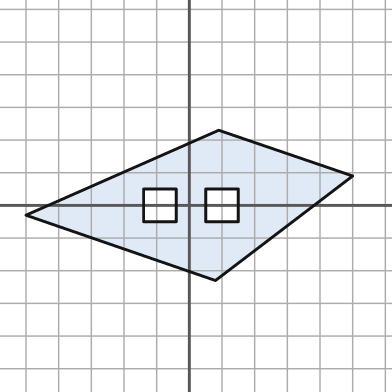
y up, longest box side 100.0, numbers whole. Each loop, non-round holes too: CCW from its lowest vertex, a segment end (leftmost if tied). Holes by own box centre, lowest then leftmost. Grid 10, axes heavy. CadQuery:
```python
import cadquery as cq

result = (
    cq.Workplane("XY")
    .moveTo(8.0, -23.0)
    .lineTo(50.0, 9.0)
    .lineTo(9.0, 23.0)
    .lineTo(-50.0, -3.0)
    .close()
    .moveTo(-14.0, -5.0)
    .lineTo(-4.0, -5.0)
    .lineTo(-4.0, 5.0)
    .lineTo(-14.0, 5.0)
    .close()
    .moveTo(5.0, -5.0)
    .lineTo(15.0, -5.0)
    .lineTo(15.0, 5.0)
    .lineTo(5.0, 5.0)
    .close()
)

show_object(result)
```